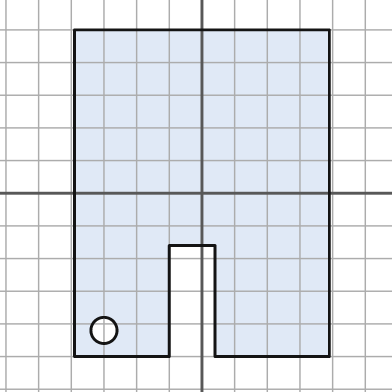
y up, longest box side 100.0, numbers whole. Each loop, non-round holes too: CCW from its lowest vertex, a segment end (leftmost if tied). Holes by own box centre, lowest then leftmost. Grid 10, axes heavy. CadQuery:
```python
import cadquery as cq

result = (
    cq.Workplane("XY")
    .moveTo(-39.0, -50.0)
    .lineTo(-10.0, -50.0)
    .lineTo(-10.0, -16.0)
    .lineTo(4.0, -16.0)
    .lineTo(4.0, -50.0)
    .lineTo(39.0, -50.0)
    .lineTo(39.0, 50.0)
    .lineTo(-39.0, 50.0)
    .close()
    .moveTo(-30.0, -42.0)
    .circle(4.0)
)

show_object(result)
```